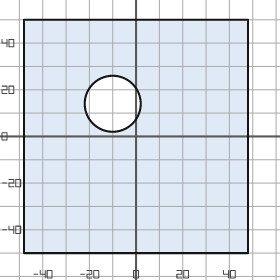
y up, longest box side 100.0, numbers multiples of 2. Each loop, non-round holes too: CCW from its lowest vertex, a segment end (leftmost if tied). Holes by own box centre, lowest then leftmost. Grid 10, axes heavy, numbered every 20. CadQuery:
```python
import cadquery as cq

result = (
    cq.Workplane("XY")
    .moveTo(-48.0, -50.0)
    .lineTo(48.0, -50.0)
    .lineTo(48.0, 50.0)
    .lineTo(-48.0, 50.0)
    .close()
    .moveTo(-10.0, 14.0)
    .circle(12.0)
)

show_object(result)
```